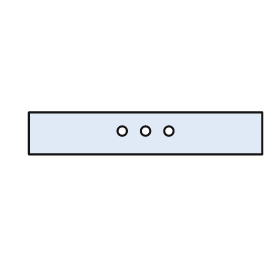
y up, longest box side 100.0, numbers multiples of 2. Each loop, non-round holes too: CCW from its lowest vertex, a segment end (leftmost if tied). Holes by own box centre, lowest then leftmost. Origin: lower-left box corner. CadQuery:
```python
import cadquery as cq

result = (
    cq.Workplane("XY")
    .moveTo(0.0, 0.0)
    .lineTo(100.0, 0.0)
    .lineTo(100.0, 18.0)
    .lineTo(0.0, 18.0)
    .close()
    .moveTo(40.0, 10.0)
    .circle(2.0)
    .moveTo(50.0, 10.0)
    .circle(2.0)
    .moveTo(60.0, 10.0)
    .circle(2.0)
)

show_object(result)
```